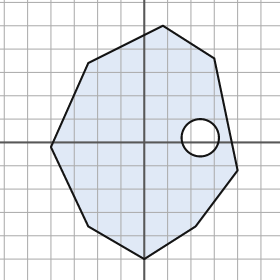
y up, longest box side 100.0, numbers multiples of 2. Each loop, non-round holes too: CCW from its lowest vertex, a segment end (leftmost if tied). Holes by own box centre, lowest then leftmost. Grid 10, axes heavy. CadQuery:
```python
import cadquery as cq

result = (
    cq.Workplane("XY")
    .moveTo(0.0, -50.0)
    .lineTo(22.0, -36.0)
    .lineTo(40.0, -12.0)
    .lineTo(30.0, 36.0)
    .lineTo(8.0, 50.0)
    .lineTo(-24.0, 34.0)
    .lineTo(-40.0, -2.0)
    .lineTo(-24.0, -36.0)
    .close()
    .moveTo(24.0, 2.0)
    .circle(8.0)
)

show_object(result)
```